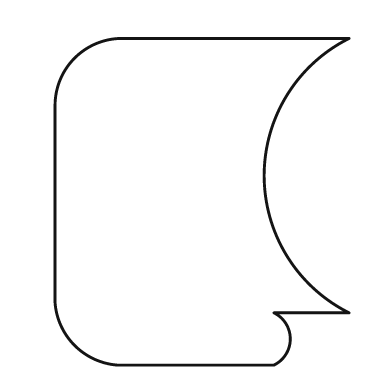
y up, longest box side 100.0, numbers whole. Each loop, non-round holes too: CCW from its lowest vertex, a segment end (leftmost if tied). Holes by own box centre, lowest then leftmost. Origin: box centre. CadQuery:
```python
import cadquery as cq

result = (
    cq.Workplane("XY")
    .moveTo(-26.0, -50.0)
    .lineTo(22.0, -50.0)
    .threePointArc((27.0, -42.0), (22.0, -34.0))
    .lineTo(45.0, -34.0)
    .threePointArc((19.0, 8.0), (45.0, 50.0))
    .lineTo(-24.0, 50.0)
    .threePointArc((-39.0, 44.0), (-45.0, 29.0))
    .lineTo(-45.0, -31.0)
    .threePointArc((-39.0, -44.0), (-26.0, -50.0))
    .close()
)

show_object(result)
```